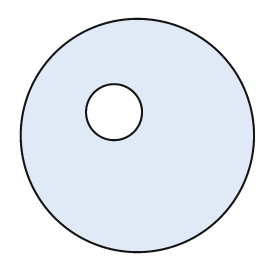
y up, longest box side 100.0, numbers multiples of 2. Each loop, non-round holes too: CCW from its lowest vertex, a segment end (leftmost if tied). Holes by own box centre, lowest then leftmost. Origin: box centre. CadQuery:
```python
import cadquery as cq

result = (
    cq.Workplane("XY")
    .moveTo(0.0, 0.0)
    .circle(50.0)
    .moveTo(-10.0, 10.0)
    .circle(12.0)
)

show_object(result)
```